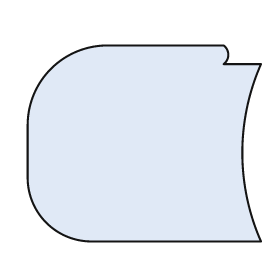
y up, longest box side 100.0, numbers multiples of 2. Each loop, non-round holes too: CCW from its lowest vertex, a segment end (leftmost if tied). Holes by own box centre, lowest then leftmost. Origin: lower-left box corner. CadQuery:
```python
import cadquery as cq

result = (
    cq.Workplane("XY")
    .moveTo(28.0, 0.0)
    .lineTo(100.0, 0.0)
    .threePointArc((92.0, 38.0), (100.0, 76.0))
    .lineTo(84.0, 76.0)
    .threePointArc((86.0, 80.0), (84.0, 84.0))
    .lineTo(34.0, 84.0)
    .threePointArc((10.0, 74.0), (0.0, 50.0))
    .lineTo(0.0, 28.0)
    .threePointArc((8.0, 8.0), (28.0, 0.0))
    .close()
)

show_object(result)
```